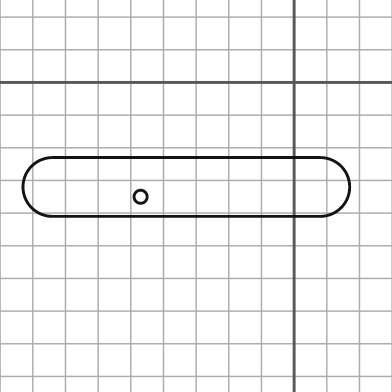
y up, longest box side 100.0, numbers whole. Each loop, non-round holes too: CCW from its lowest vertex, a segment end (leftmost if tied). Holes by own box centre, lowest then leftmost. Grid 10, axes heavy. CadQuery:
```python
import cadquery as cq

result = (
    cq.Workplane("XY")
    .moveTo(-74.0, -41.0)
    .lineTo(8.0, -41.0)
    .threePointArc((17.0, -32.0), (8.0, -23.0))
    .lineTo(-74.0, -23.0)
    .threePointArc((-83.0, -32.0), (-74.0, -41.0))
    .close()
    .moveTo(-47.0, -35.0)
    .circle(2.0)
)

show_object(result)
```